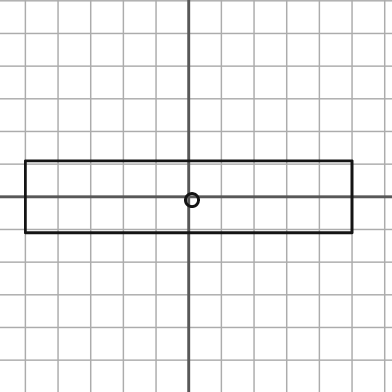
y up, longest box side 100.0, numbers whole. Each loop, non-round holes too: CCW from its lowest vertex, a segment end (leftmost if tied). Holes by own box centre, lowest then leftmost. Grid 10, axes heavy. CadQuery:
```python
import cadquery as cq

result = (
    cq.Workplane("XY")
    .moveTo(-50.0, -11.0)
    .lineTo(50.0, -11.0)
    .lineTo(50.0, 11.0)
    .lineTo(-50.0, 11.0)
    .close()
    .moveTo(1.0, -1.0)
    .circle(2.0)
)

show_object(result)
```